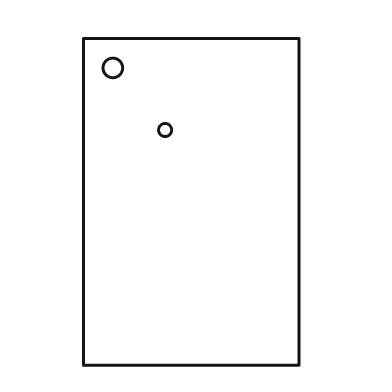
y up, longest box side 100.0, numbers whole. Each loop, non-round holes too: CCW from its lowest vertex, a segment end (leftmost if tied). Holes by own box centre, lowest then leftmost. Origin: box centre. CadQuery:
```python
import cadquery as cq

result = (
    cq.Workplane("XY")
    .moveTo(-33.0, -50.0)
    .lineTo(33.0, -50.0)
    .lineTo(33.0, 50.0)
    .lineTo(-33.0, 50.0)
    .close()
    .moveTo(-8.0, 22.0)
    .circle(2.0)
    .moveTo(-24.0, 41.0)
    .circle(3.0)
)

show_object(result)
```